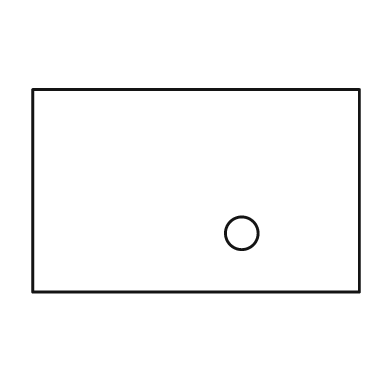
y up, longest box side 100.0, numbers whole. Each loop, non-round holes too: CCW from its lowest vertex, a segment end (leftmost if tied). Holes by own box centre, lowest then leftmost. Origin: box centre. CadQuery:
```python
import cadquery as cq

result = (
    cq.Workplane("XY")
    .moveTo(-50.0, -31.0)
    .lineTo(50.0, -31.0)
    .lineTo(50.0, 31.0)
    .lineTo(-50.0, 31.0)
    .close()
    .moveTo(14.0, -13.0)
    .circle(5.0)
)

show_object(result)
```